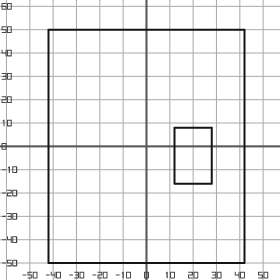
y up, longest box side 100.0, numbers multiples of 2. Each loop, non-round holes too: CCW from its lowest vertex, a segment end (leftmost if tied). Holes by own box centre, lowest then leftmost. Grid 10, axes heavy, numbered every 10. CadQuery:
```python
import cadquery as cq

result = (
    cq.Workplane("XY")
    .moveTo(-42.0, -50.0)
    .lineTo(42.0, -50.0)
    .lineTo(42.0, 50.0)
    .lineTo(-42.0, 50.0)
    .close()
    .moveTo(12.0, -16.0)
    .lineTo(28.0, -16.0)
    .lineTo(28.0, 8.0)
    .lineTo(12.0, 8.0)
    .close()
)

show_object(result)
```